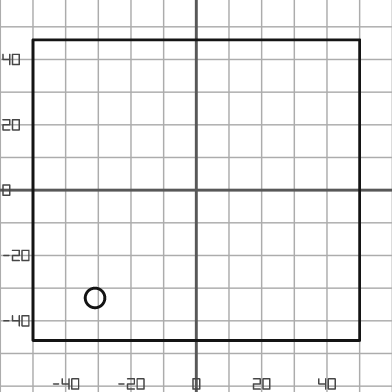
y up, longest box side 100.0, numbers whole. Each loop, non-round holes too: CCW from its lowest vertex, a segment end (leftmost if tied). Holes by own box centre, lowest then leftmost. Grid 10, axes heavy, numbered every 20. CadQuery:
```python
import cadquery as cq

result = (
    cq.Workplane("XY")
    .moveTo(-50.0, -46.0)
    .lineTo(50.0, -46.0)
    .lineTo(50.0, 46.0)
    .lineTo(-50.0, 46.0)
    .close()
    .moveTo(-31.0, -33.0)
    .circle(3.0)
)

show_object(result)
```